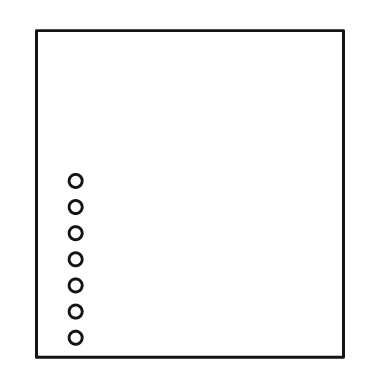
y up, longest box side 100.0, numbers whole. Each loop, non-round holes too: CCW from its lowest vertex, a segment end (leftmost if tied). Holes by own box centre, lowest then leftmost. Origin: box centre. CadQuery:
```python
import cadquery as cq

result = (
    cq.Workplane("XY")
    .moveTo(-47.0, -50.0)
    .lineTo(47.0, -50.0)
    .lineTo(47.0, 50.0)
    .lineTo(-47.0, 50.0)
    .close()
    .moveTo(-35.0, -44.0)
    .circle(2.0)
    .moveTo(-35.0, -36.0)
    .circle(2.0)
    .moveTo(-35.0, -28.0)
    .circle(2.0)
    .moveTo(-35.0, -20.0)
    .circle(2.0)
    .moveTo(-35.0, -12.0)
    .circle(2.0)
    .moveTo(-35.0, -4.0)
    .circle(2.0)
    .moveTo(-35.0, 4.0)
    .circle(2.0)
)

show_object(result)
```